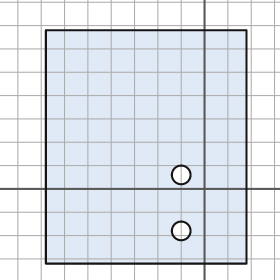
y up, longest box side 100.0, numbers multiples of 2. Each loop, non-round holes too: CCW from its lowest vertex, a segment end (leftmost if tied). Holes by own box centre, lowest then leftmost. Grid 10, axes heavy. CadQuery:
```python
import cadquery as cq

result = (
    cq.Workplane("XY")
    .moveTo(-68.0, -32.0)
    .lineTo(18.0, -32.0)
    .lineTo(18.0, 68.0)
    .lineTo(-68.0, 68.0)
    .close()
    .moveTo(-10.0, -18.0)
    .circle(4.0)
    .moveTo(-10.0, 6.0)
    .circle(4.0)
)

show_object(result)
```